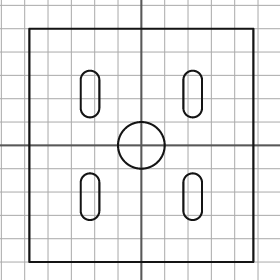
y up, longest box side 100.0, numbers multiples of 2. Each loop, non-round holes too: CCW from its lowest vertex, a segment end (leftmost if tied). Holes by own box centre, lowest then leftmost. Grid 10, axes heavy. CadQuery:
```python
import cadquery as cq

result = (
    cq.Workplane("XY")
    .moveTo(-48.0, -50.0)
    .lineTo(48.0, -50.0)
    .lineTo(48.0, 50.0)
    .lineTo(-48.0, 50.0)
    .close()
    .moveTo(-26.0, -28.0)
    .threePointArc((-22.0, -32.0), (-18.0, -28.0))
    .lineTo(-18.0, -16.0)
    .threePointArc((-22.0, -12.0), (-26.0, -16.0))
    .close()
    .moveTo(18.0, -28.0)
    .threePointArc((22.0, -32.0), (26.0, -28.0))
    .lineTo(26.0, -16.0)
    .threePointArc((22.0, -12.0), (18.0, -16.0))
    .close()
    .moveTo(0.0, 0.0)
    .circle(10.0)
    .moveTo(-26.0, 16.0)
    .threePointArc((-22.0, 12.0), (-18.0, 16.0))
    .lineTo(-18.0, 28.0)
    .threePointArc((-22.0, 32.0), (-26.0, 28.0))
    .close()
    .moveTo(18.0, 16.0)
    .threePointArc((22.0, 12.0), (26.0, 16.0))
    .lineTo(26.0, 28.0)
    .threePointArc((22.0, 32.0), (18.0, 28.0))
    .close()
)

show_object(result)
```